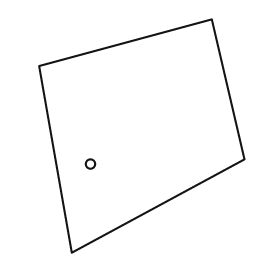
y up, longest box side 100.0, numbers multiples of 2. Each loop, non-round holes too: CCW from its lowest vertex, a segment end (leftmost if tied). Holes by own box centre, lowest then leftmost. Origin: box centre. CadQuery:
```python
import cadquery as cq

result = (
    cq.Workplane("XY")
    .moveTo(-30.0, -50.0)
    .lineTo(44.0, -10.0)
    .lineTo(30.0, 50.0)
    .lineTo(-44.0, 30.0)
    .close()
    .moveTo(-22.0, -12.0)
    .circle(2.0)
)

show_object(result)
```